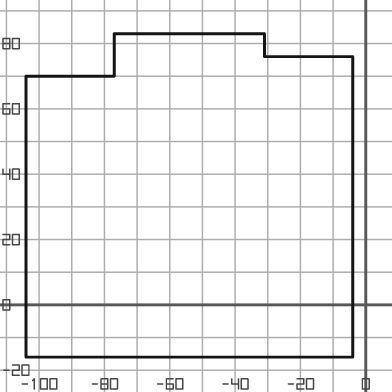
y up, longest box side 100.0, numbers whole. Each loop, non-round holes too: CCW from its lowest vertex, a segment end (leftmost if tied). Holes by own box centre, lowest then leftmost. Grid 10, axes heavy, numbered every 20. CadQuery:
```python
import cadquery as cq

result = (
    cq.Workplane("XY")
    .moveTo(-104.0, -16.0)
    .lineTo(-4.0, -16.0)
    .lineTo(-4.0, 76.0)
    .lineTo(-31.0, 76.0)
    .lineTo(-31.0, 83.0)
    .lineTo(-77.0, 83.0)
    .lineTo(-77.0, 70.0)
    .lineTo(-104.0, 70.0)
    .close()
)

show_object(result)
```